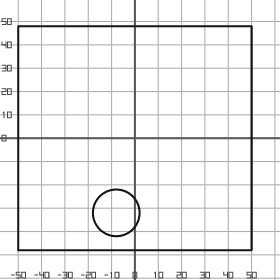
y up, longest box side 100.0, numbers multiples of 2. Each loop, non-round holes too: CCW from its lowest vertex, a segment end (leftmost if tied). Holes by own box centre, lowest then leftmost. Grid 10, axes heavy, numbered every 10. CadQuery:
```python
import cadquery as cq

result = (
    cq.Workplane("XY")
    .moveTo(-50.0, -48.0)
    .lineTo(50.0, -48.0)
    .lineTo(50.0, 48.0)
    .lineTo(-50.0, 48.0)
    .close()
    .moveTo(-8.0, -32.0)
    .circle(10.0)
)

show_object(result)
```